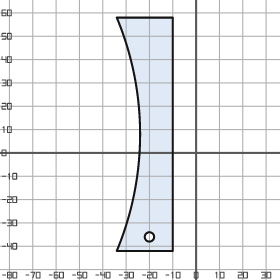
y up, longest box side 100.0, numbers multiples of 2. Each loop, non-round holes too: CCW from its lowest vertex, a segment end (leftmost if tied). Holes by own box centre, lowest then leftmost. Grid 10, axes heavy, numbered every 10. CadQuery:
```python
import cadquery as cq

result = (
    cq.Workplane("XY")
    .moveTo(-34.0, -42.0)
    .lineTo(-10.0, -42.0)
    .lineTo(-10.0, 58.0)
    .lineTo(-34.0, 58.0)
    .threePointArc((-24.0, 8.0), (-34.0, -42.0))
    .close()
    .moveTo(-20.0, -36.0)
    .circle(2.0)
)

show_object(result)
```